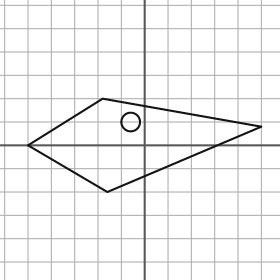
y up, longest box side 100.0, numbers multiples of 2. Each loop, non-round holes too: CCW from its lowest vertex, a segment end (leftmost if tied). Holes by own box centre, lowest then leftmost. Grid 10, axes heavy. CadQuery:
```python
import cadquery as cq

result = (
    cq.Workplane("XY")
    .moveTo(-16.0, -20.0)
    .lineTo(50.0, 8.0)
    .lineTo(-18.0, 20.0)
    .lineTo(-50.0, 0.0)
    .close()
    .moveTo(-6.0, 10.0)
    .circle(4.0)
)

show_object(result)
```